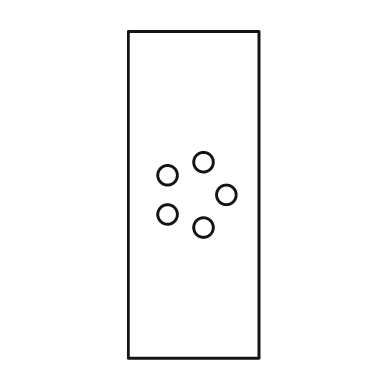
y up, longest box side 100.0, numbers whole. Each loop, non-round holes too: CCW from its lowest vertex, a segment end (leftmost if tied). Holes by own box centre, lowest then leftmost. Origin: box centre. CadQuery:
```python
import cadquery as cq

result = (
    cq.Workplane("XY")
    .moveTo(-20.0, -50.0)
    .lineTo(20.0, -50.0)
    .lineTo(20.0, 50.0)
    .lineTo(-20.0, 50.0)
    .close()
    .moveTo(3.0, -10.0)
    .circle(3.0)
    .moveTo(-8.0, -6.0)
    .circle(3.0)
    .moveTo(10.0, 0.0)
    .circle(3.0)
    .moveTo(-8.0, 6.0)
    .circle(3.0)
    .moveTo(3.0, 10.0)
    .circle(3.0)
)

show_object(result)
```